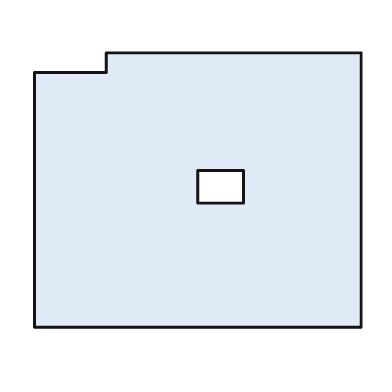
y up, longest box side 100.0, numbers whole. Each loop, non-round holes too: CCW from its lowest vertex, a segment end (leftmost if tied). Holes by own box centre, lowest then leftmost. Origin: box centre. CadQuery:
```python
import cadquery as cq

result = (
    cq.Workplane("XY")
    .moveTo(-50.0, -42.0)
    .lineTo(50.0, -42.0)
    .lineTo(50.0, 42.0)
    .lineTo(-28.0, 42.0)
    .lineTo(-28.0, 36.0)
    .lineTo(-50.0, 36.0)
    .close()
    .moveTo(0.0, -4.0)
    .lineTo(14.0, -4.0)
    .lineTo(14.0, 6.0)
    .lineTo(0.0, 6.0)
    .close()
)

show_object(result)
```